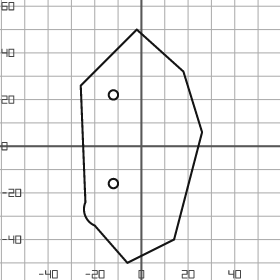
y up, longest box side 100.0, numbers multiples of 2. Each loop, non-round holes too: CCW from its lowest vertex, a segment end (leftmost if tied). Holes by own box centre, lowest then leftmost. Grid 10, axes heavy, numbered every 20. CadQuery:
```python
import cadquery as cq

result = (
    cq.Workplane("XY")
    .moveTo(-6.0, -50.0)
    .lineTo(14.0, -40.0)
    .lineTo(26.0, 6.0)
    .lineTo(18.0, 32.0)
    .lineTo(-2.0, 50.0)
    .lineTo(-26.0, 26.0)
    .lineTo(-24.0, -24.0)
    .threePointArc((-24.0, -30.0), (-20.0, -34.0))
    .close()
    .moveTo(-12.0, -16.0)
    .circle(2.0)
    .moveTo(-12.0, 22.0)
    .circle(2.0)
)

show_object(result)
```